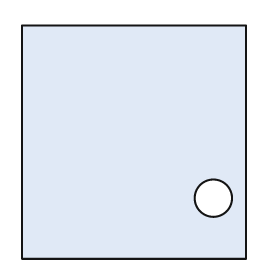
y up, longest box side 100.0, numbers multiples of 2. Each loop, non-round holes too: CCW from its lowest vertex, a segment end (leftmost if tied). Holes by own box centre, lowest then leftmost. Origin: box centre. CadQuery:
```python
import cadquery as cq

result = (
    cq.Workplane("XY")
    .moveTo(-48.0, -50.0)
    .lineTo(48.0, -50.0)
    .lineTo(48.0, 50.0)
    .lineTo(-48.0, 50.0)
    .close()
    .moveTo(34.0, -24.0)
    .circle(8.0)
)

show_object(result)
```